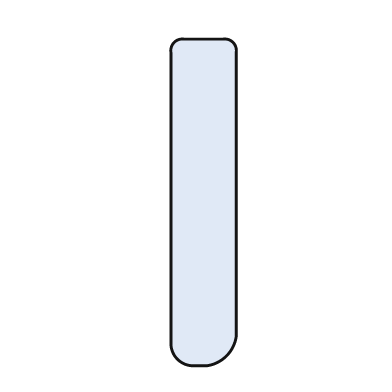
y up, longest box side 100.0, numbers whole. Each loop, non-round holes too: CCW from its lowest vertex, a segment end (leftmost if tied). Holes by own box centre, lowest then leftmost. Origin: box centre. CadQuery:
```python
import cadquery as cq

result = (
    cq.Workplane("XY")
    .moveTo(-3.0, -50.0)
    .lineTo(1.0, -50.0)
    .threePointArc((7.0, -47.0), (10.0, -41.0))
    .lineTo(10.0, 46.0)
    .threePointArc((9.0, 49.0), (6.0, 50.0))
    .lineTo(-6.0, 50.0)
    .threePointArc((-9.0, 49.0), (-10.0, 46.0))
    .lineTo(-10.0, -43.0)
    .threePointArc((-8.0, -48.0), (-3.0, -50.0))
    .close()
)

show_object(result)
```